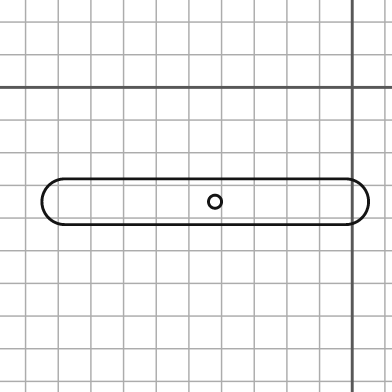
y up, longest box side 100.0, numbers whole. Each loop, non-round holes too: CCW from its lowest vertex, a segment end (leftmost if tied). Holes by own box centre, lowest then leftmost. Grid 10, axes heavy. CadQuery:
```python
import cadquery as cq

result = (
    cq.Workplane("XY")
    .moveTo(-88.0, -42.0)
    .lineTo(-2.0, -42.0)
    .threePointArc((5.0, -35.0), (-2.0, -28.0))
    .lineTo(-88.0, -28.0)
    .threePointArc((-95.0, -35.0), (-88.0, -42.0))
    .close()
    .moveTo(-42.0, -35.0)
    .circle(2.0)
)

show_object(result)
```